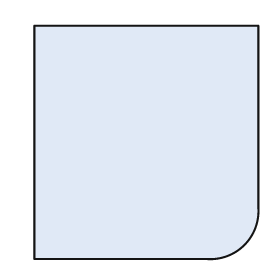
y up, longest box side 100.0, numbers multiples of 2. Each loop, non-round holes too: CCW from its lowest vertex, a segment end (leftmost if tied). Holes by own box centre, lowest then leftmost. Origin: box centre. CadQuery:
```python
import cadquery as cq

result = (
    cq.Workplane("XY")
    .moveTo(-48.0, -50.0)
    .lineTo(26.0, -50.0)
    .threePointArc((42.0, -44.0), (48.0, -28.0))
    .lineTo(48.0, 50.0)
    .lineTo(-48.0, 50.0)
    .close()
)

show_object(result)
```